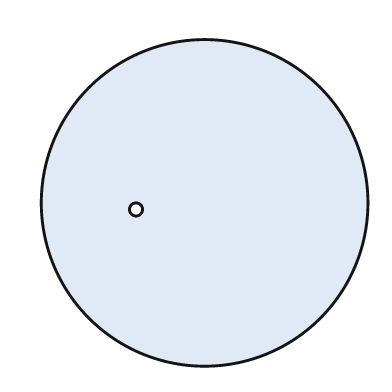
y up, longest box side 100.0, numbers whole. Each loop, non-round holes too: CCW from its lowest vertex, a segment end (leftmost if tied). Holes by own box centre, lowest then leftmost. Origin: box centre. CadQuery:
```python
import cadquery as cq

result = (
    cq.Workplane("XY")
    .moveTo(0.0, 0.0)
    .circle(50.0)
    .moveTo(-21.0, -2.0)
    .circle(2.0)
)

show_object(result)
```